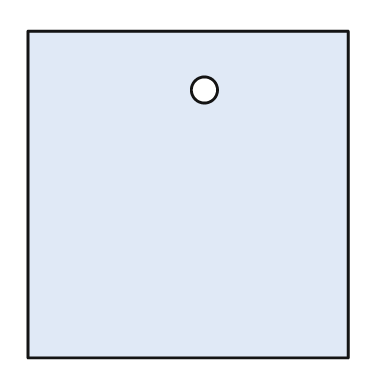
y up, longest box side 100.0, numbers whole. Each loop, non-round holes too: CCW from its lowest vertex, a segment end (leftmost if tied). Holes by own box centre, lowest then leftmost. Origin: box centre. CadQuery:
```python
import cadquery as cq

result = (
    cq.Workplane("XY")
    .moveTo(-49.0, -50.0)
    .lineTo(49.0, -50.0)
    .lineTo(49.0, 50.0)
    .lineTo(-49.0, 50.0)
    .close()
    .moveTo(5.0, 32.0)
    .circle(4.0)
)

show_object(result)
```